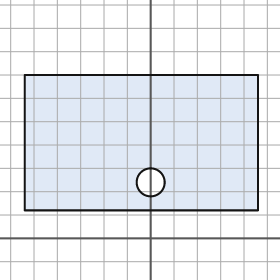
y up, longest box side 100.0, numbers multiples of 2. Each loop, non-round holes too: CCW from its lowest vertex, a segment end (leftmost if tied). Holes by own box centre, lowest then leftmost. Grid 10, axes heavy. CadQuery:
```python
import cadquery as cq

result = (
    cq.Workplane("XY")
    .moveTo(-54.0, 12.0)
    .lineTo(46.0, 12.0)
    .lineTo(46.0, 70.0)
    .lineTo(-54.0, 70.0)
    .close()
    .moveTo(0.0, 24.0)
    .circle(6.0)
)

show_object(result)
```